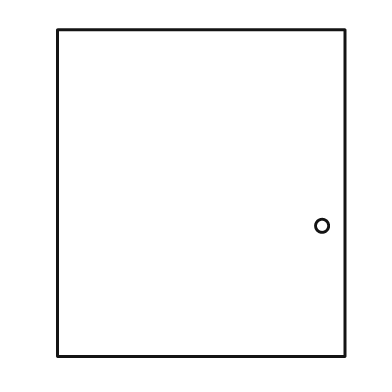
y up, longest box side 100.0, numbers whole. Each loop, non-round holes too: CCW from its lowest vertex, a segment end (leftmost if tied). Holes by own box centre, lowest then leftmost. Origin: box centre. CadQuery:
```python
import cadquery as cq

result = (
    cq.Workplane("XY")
    .moveTo(-44.0, -50.0)
    .lineTo(44.0, -50.0)
    .lineTo(44.0, 50.0)
    .lineTo(-44.0, 50.0)
    .close()
    .moveTo(37.0, -10.0)
    .circle(2.0)
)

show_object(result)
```